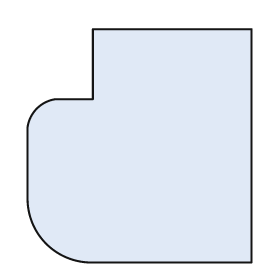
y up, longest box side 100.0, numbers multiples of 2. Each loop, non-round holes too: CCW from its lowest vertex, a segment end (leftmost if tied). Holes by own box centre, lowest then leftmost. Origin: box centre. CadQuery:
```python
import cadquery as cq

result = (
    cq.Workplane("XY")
    .moveTo(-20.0, -50.0)
    .lineTo(48.0, -50.0)
    .lineTo(48.0, 50.0)
    .lineTo(-20.0, 50.0)
    .lineTo(-20.0, 20.0)
    .lineTo(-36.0, 20.0)
    .threePointArc((-44.0, 16.0), (-48.0, 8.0))
    .lineTo(-48.0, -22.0)
    .threePointArc((-40.0, -42.0), (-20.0, -50.0))
    .close()
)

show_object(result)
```